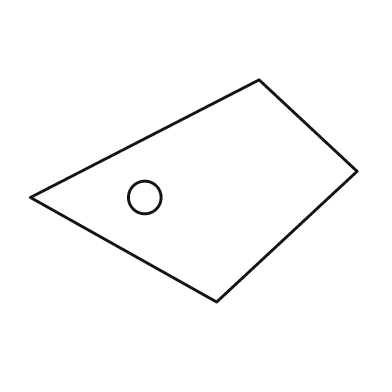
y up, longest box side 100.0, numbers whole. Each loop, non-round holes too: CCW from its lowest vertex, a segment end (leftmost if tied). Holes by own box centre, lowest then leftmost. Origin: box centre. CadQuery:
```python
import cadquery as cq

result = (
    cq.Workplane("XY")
    .moveTo(7.0, -34.0)
    .lineTo(50.0, 6.0)
    .lineTo(20.0, 34.0)
    .lineTo(-50.0, -2.0)
    .close()
    .moveTo(-15.0, -2.0)
    .circle(5.0)
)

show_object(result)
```